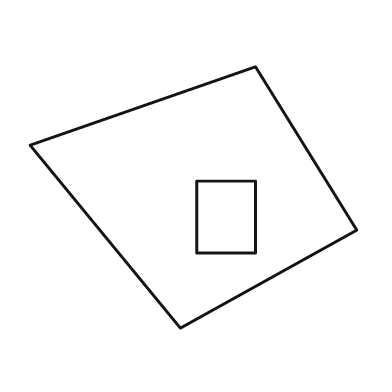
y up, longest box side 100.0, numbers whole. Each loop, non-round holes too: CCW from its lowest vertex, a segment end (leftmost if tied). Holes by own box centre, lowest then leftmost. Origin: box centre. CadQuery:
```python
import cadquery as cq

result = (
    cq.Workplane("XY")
    .moveTo(-4.0, -40.0)
    .lineTo(50.0, -10.0)
    .lineTo(19.0, 40.0)
    .lineTo(-50.0, 16.0)
    .close()
    .moveTo(1.0, -17.0)
    .lineTo(19.0, -17.0)
    .lineTo(19.0, 5.0)
    .lineTo(1.0, 5.0)
    .close()
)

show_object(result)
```